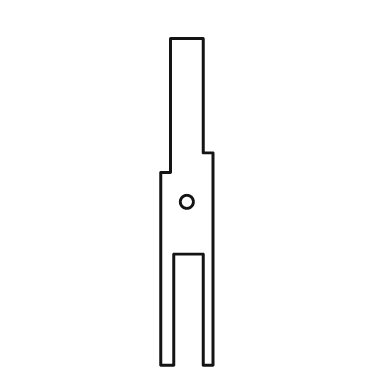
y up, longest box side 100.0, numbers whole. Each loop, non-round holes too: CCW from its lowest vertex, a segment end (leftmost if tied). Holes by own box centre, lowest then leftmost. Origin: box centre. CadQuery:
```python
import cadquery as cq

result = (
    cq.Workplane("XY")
    .moveTo(-8.0, -50.0)
    .lineTo(-4.0, -50.0)
    .lineTo(-4.0, -16.0)
    .lineTo(5.0, -16.0)
    .lineTo(5.0, -50.0)
    .lineTo(8.0, -50.0)
    .lineTo(8.0, 15.0)
    .lineTo(5.0, 15.0)
    .lineTo(5.0, 50.0)
    .lineTo(-5.0, 50.0)
    .lineTo(-5.0, 9.0)
    .lineTo(-8.0, 9.0)
    .close()
    .moveTo(0.0, 0.0)
    .circle(2.0)
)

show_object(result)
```